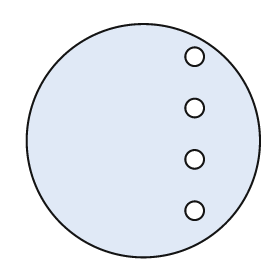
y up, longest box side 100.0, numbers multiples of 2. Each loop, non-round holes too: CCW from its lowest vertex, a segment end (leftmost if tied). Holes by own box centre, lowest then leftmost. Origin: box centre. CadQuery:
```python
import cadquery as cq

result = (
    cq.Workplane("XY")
    .moveTo(0.0, 0.0)
    .circle(50.0)
    .moveTo(22.0, -30.0)
    .circle(4.0)
    .moveTo(22.0, -8.0)
    .circle(4.0)
    .moveTo(22.0, 14.0)
    .circle(4.0)
    .moveTo(22.0, 36.0)
    .circle(4.0)
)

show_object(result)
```